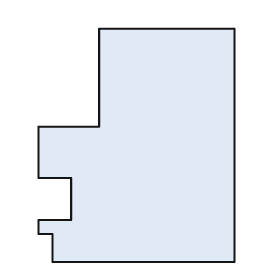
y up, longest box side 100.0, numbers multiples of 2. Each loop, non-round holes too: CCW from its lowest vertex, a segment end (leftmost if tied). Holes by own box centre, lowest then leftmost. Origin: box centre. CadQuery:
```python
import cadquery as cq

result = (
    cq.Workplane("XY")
    .moveTo(-36.0, -50.0)
    .lineTo(42.0, -50.0)
    .lineTo(42.0, 50.0)
    .lineTo(-16.0, 50.0)
    .lineTo(-16.0, 8.0)
    .lineTo(-42.0, 8.0)
    .lineTo(-42.0, -14.0)
    .lineTo(-28.0, -14.0)
    .lineTo(-28.0, -32.0)
    .lineTo(-42.0, -32.0)
    .lineTo(-42.0, -38.0)
    .lineTo(-36.0, -38.0)
    .close()
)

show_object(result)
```